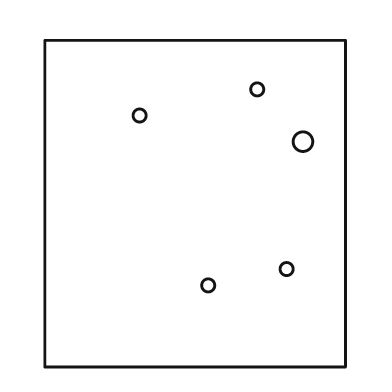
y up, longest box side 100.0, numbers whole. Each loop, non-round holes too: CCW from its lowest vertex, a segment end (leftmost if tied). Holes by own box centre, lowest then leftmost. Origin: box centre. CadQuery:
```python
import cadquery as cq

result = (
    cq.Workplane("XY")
    .moveTo(-46.0, -50.0)
    .lineTo(46.0, -50.0)
    .lineTo(46.0, 50.0)
    .lineTo(-46.0, 50.0)
    .close()
    .moveTo(4.0, -25.0)
    .circle(2.0)
    .moveTo(28.0, -20.0)
    .circle(2.0)
    .moveTo(33.0, 19.0)
    .circle(3.0)
    .moveTo(-17.0, 27.0)
    .circle(2.0)
    .moveTo(19.0, 35.0)
    .circle(2.0)
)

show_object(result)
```